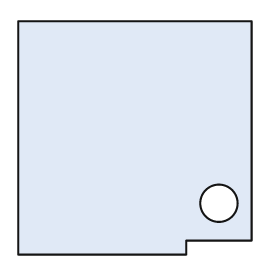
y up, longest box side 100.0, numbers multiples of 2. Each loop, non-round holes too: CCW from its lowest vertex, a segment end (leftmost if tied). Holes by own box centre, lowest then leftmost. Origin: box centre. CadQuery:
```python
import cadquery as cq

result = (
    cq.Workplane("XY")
    .moveTo(-50.0, -50.0)
    .lineTo(22.0, -50.0)
    .lineTo(22.0, -44.0)
    .lineTo(50.0, -44.0)
    .lineTo(50.0, 50.0)
    .lineTo(-50.0, 50.0)
    .close()
    .moveTo(36.0, -28.0)
    .circle(8.0)
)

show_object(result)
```